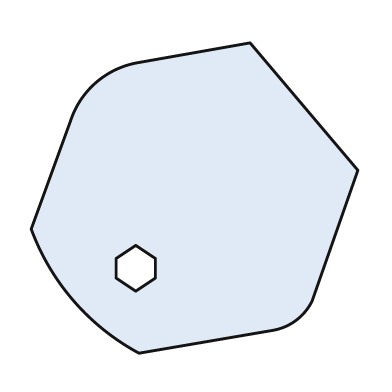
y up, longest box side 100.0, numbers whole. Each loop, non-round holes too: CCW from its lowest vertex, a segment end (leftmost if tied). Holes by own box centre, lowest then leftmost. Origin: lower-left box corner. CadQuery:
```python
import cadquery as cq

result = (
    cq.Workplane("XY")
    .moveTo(33.0, 0.0)
    .lineTo(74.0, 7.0)
    .threePointArc((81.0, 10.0), (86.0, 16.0))
    .lineTo(100.0, 56.0)
    .lineTo(67.0, 95.0)
    .lineTo(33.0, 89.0)
    .threePointArc((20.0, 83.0), (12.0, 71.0))
    .lineTo(0.0, 38.0)
    .threePointArc((13.0, 16.0), (33.0, 0.0))
    .close()
    .moveTo(32.0, 19.0)
    .lineTo(38.0, 23.0)
    .lineTo(38.0, 29.0)
    .lineTo(32.0, 33.0)
    .lineTo(26.0, 29.0)
    .lineTo(26.0, 23.0)
    .close()
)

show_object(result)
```